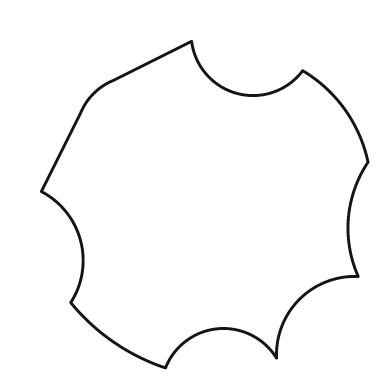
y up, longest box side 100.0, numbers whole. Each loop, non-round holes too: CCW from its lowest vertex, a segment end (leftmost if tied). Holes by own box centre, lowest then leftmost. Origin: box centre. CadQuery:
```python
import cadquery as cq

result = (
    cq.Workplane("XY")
    .moveTo(-12.0, -50.0)
    .threePointArc((4.0, -38.0), (22.0, -47.0))
    .threePointArc((29.0, -29.0), (47.0, -22.0))
    .threePointArc((44.0, -4.0), (50.0, 13.0))
    .threePointArc((43.0, 29.0), (30.0, 41.0))
    .threePointArc((10.0, 34.0), (-4.0, 50.0))
    .lineTo(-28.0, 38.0)
    .threePointArc((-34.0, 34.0), (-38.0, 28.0))
    .lineTo(-50.0, 4.0)
    .threePointArc((-38.0, -11.0), (-41.0, -30.0))
    .threePointArc((-28.0, -42.0), (-12.0, -50.0))
    .close()
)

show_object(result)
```